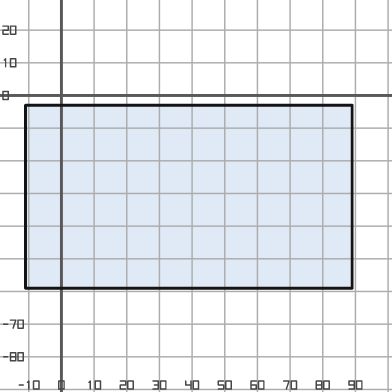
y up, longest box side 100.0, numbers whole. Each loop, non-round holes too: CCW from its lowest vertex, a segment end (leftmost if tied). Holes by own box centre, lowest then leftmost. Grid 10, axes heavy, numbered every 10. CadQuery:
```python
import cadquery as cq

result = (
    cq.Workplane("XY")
    .moveTo(-11.0, -59.0)
    .lineTo(89.0, -59.0)
    .lineTo(89.0, -3.0)
    .lineTo(-11.0, -3.0)
    .close()
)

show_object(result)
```